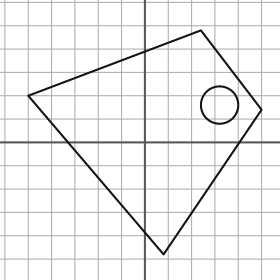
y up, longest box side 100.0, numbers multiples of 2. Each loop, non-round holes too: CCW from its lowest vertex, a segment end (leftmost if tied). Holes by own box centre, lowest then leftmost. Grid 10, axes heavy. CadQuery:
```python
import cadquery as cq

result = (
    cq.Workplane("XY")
    .moveTo(8.0, -48.0)
    .lineTo(50.0, 14.0)
    .lineTo(24.0, 48.0)
    .lineTo(-50.0, 20.0)
    .close()
    .moveTo(32.0, 16.0)
    .circle(8.0)
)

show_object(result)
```